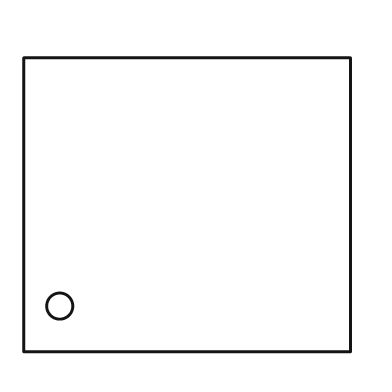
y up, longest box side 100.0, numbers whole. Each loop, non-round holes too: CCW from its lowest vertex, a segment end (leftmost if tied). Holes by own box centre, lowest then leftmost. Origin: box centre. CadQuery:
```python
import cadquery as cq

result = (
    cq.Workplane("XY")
    .moveTo(-50.0, -45.0)
    .lineTo(50.0, -45.0)
    .lineTo(50.0, 45.0)
    .lineTo(-50.0, 45.0)
    .close()
    .moveTo(-39.0, -31.0)
    .circle(4.0)
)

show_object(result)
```